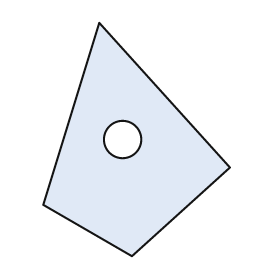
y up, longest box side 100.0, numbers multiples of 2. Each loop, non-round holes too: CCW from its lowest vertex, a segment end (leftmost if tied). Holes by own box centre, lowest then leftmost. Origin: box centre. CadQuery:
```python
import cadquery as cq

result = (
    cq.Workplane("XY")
    .moveTo(-2.0, -50.0)
    .lineTo(40.0, -12.0)
    .lineTo(-16.0, 50.0)
    .lineTo(-40.0, -28.0)
    .close()
    .moveTo(-6.0, 0.0)
    .circle(8.0)
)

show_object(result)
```